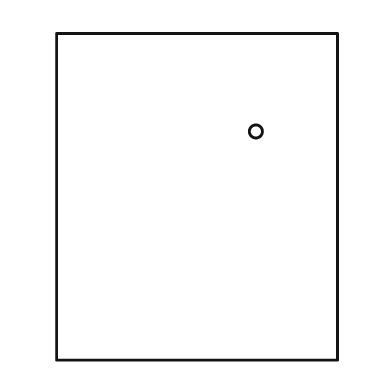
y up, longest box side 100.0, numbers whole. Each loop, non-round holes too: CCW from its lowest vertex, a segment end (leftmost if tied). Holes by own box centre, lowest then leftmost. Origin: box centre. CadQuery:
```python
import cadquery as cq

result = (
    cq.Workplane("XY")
    .moveTo(-43.0, -50.0)
    .lineTo(43.0, -50.0)
    .lineTo(43.0, 50.0)
    .lineTo(-43.0, 50.0)
    .close()
    .moveTo(18.0, 20.0)
    .circle(2.0)
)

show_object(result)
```